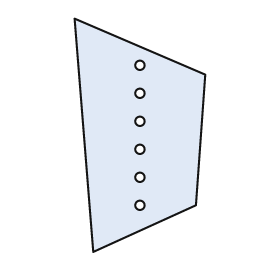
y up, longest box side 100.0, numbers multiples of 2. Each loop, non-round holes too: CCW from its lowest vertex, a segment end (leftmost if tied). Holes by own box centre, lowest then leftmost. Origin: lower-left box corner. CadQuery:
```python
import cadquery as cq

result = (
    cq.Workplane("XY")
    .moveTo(8.0, 0.0)
    .lineTo(52.0, 20.0)
    .lineTo(56.0, 76.0)
    .lineTo(0.0, 100.0)
    .close()
    .moveTo(28.0, 20.0)
    .circle(2.0)
    .moveTo(28.0, 32.0)
    .circle(2.0)
    .moveTo(28.0, 44.0)
    .circle(2.0)
    .moveTo(28.0, 56.0)
    .circle(2.0)
    .moveTo(28.0, 68.0)
    .circle(2.0)
    .moveTo(28.0, 80.0)
    .circle(2.0)
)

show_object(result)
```